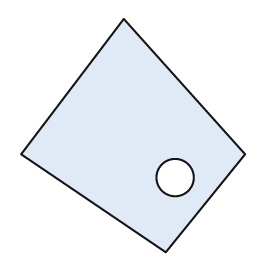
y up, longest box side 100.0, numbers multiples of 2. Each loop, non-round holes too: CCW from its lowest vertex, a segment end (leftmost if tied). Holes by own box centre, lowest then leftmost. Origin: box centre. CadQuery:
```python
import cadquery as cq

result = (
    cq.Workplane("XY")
    .moveTo(14.0, -50.0)
    .lineTo(48.0, -8.0)
    .lineTo(-4.0, 50.0)
    .lineTo(-48.0, -8.0)
    .close()
    .moveTo(18.0, -18.0)
    .circle(8.0)
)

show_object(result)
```